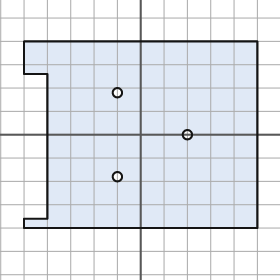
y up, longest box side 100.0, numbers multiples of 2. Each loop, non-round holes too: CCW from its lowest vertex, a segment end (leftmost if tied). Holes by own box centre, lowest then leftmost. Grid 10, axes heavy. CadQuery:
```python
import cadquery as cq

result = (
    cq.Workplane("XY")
    .moveTo(-50.0, -40.0)
    .lineTo(50.0, -40.0)
    .lineTo(50.0, 40.0)
    .lineTo(-50.0, 40.0)
    .lineTo(-50.0, 26.0)
    .lineTo(-40.0, 26.0)
    .lineTo(-40.0, -36.0)
    .lineTo(-50.0, -36.0)
    .close()
    .moveTo(-10.0, -18.0)
    .circle(2.0)
    .moveTo(20.0, 0.0)
    .circle(2.0)
    .moveTo(-10.0, 18.0)
    .circle(2.0)
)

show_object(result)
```